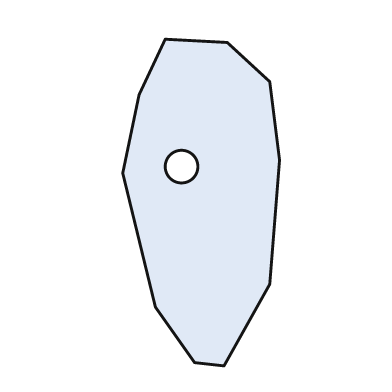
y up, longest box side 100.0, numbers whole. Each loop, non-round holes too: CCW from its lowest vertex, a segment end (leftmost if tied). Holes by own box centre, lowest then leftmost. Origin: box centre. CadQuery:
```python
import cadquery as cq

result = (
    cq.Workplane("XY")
    .moveTo(7.0, -50.0)
    .lineTo(21.0, -25.0)
    .lineTo(24.0, 13.0)
    .lineTo(21.0, 37.0)
    .lineTo(8.0, 49.0)
    .lineTo(-11.0, 50.0)
    .lineTo(-19.0, 33.0)
    .lineTo(-24.0, 9.0)
    .lineTo(-14.0, -32.0)
    .lineTo(-2.0, -49.0)
    .close()
    .moveTo(-6.0, 11.0)
    .circle(5.0)
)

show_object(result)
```